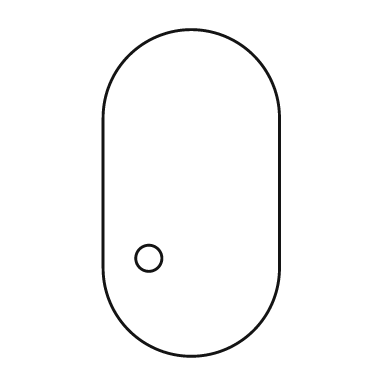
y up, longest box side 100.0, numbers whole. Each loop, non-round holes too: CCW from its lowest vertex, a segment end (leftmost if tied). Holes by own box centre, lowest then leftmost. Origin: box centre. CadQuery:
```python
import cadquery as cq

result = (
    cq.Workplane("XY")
    .moveTo(-27.0, -23.0)
    .threePointArc((0.0, -50.0), (27.0, -23.0))
    .lineTo(27.0, 23.0)
    .threePointArc((0.0, 50.0), (-27.0, 23.0))
    .close()
    .moveTo(-13.0, -20.0)
    .circle(4.0)
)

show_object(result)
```